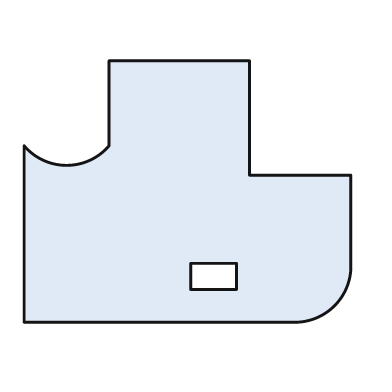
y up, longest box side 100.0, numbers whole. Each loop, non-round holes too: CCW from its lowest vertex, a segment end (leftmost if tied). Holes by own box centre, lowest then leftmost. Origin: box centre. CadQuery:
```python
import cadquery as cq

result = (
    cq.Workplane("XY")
    .moveTo(-50.0, -40.0)
    .lineTo(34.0, -40.0)
    .threePointArc((45.0, -35.0), (50.0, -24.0))
    .lineTo(50.0, 5.0)
    .lineTo(19.0, 5.0)
    .lineTo(19.0, 40.0)
    .lineTo(-24.0, 40.0)
    .lineTo(-24.0, 14.0)
    .threePointArc((-37.0, 8.0), (-50.0, 14.0))
    .close()
    .moveTo(1.0, -30.0)
    .lineTo(15.0, -30.0)
    .lineTo(15.0, -22.0)
    .lineTo(1.0, -22.0)
    .close()
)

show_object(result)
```